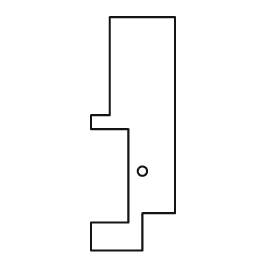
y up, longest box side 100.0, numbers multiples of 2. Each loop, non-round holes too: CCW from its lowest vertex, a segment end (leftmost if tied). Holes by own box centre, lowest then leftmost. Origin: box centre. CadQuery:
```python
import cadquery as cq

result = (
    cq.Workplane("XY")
    .moveTo(-18.0, -50.0)
    .lineTo(4.0, -50.0)
    .lineTo(4.0, -34.0)
    .lineTo(18.0, -34.0)
    .lineTo(18.0, 50.0)
    .lineTo(-10.0, 50.0)
    .lineTo(-10.0, 8.0)
    .lineTo(-18.0, 8.0)
    .lineTo(-18.0, 2.0)
    .lineTo(-2.0, 2.0)
    .lineTo(-2.0, -38.0)
    .lineTo(-18.0, -38.0)
    .close()
    .moveTo(4.0, -16.0)
    .circle(2.0)
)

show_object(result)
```